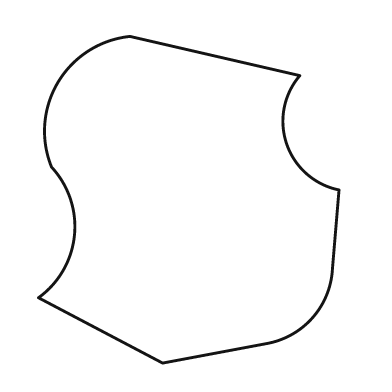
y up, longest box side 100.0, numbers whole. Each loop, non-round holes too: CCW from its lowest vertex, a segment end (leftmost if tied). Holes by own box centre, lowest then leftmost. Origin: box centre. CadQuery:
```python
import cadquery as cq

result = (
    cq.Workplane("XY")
    .moveTo(-8.0, -50.0)
    .lineTo(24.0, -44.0)
    .threePointArc((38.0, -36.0), (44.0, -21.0))
    .lineTo(46.0, 3.0)
    .threePointArc((30.0, 17.0), (34.0, 38.0))
    .lineTo(-18.0, 50.0)
    .threePointArc((-40.0, 36.0), (-42.0, 10.0))
    .threePointArc((-35.0, -11.0), (-46.0, -30.0))
    .close()
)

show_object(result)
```